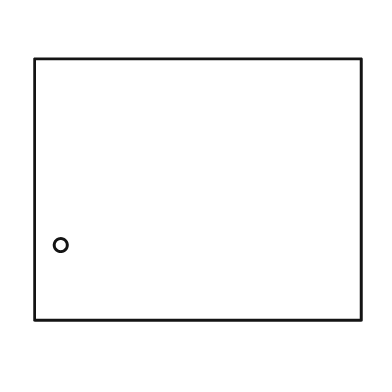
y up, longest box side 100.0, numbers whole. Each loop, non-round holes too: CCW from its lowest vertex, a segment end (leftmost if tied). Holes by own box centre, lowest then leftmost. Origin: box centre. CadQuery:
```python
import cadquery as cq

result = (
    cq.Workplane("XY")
    .moveTo(-50.0, -40.0)
    .lineTo(50.0, -40.0)
    .lineTo(50.0, 40.0)
    .lineTo(-50.0, 40.0)
    .close()
    .moveTo(-42.0, -17.0)
    .circle(2.0)
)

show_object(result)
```